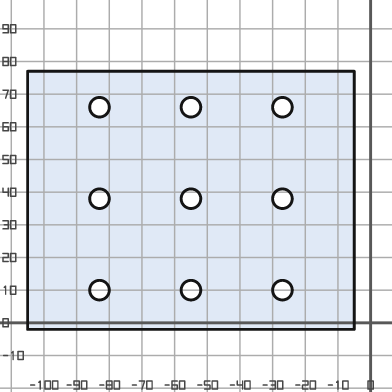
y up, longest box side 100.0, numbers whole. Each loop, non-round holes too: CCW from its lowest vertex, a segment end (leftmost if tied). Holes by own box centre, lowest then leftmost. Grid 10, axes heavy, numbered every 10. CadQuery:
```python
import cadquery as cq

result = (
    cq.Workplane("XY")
    .moveTo(-105.0, -2.0)
    .lineTo(-5.0, -2.0)
    .lineTo(-5.0, 77.0)
    .lineTo(-105.0, 77.0)
    .close()
    .moveTo(-83.0, 10.0)
    .circle(3.0)
    .moveTo(-55.0, 10.0)
    .circle(3.0)
    .moveTo(-27.0, 10.0)
    .circle(3.0)
    .moveTo(-83.0, 38.0)
    .circle(3.0)
    .moveTo(-55.0, 38.0)
    .circle(3.0)
    .moveTo(-27.0, 38.0)
    .circle(3.0)
    .moveTo(-83.0, 66.0)
    .circle(3.0)
    .moveTo(-55.0, 66.0)
    .circle(3.0)
    .moveTo(-27.0, 66.0)
    .circle(3.0)
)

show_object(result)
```